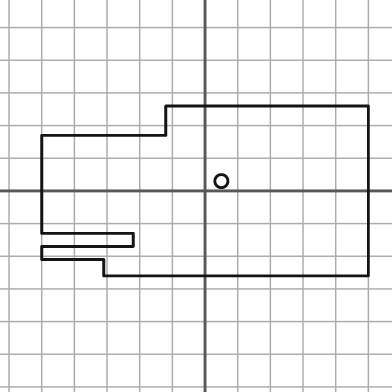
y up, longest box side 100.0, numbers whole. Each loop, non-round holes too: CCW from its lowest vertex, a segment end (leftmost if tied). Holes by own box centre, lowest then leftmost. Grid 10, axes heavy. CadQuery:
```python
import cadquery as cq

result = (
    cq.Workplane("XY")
    .moveTo(-31.0, -26.0)
    .lineTo(50.0, -26.0)
    .lineTo(50.0, 26.0)
    .lineTo(-12.0, 26.0)
    .lineTo(-12.0, 17.0)
    .lineTo(-50.0, 17.0)
    .lineTo(-50.0, -13.0)
    .lineTo(-22.0, -13.0)
    .lineTo(-22.0, -17.0)
    .lineTo(-50.0, -17.0)
    .lineTo(-50.0, -21.0)
    .lineTo(-31.0, -21.0)
    .close()
    .moveTo(5.0, 3.0)
    .circle(2.0)
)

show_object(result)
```